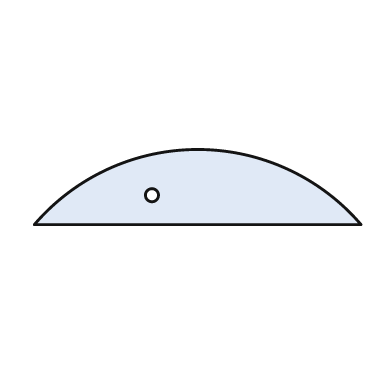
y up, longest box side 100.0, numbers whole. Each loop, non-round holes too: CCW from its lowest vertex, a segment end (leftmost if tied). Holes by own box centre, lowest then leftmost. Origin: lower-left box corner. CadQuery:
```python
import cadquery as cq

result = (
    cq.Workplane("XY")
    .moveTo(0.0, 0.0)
    .lineTo(100.0, 0.0)
    .threePointArc((50.0, 23.0), (0.0, 0.0))
    .close()
    .moveTo(36.0, 9.0)
    .circle(2.0)
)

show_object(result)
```